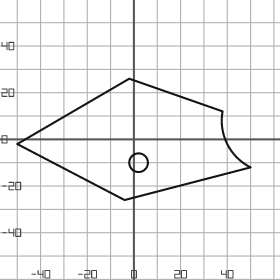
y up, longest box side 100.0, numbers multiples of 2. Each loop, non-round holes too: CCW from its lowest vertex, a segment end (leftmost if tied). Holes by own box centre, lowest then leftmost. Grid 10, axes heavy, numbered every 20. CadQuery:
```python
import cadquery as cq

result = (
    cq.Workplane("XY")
    .moveTo(-4.0, -26.0)
    .lineTo(50.0, -12.0)
    .threePointArc((40.0, -2.0), (38.0, 12.0))
    .lineTo(-2.0, 26.0)
    .lineTo(-50.0, -2.0)
    .close()
    .moveTo(2.0, -10.0)
    .circle(4.0)
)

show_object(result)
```